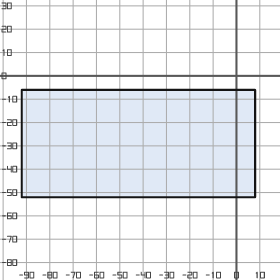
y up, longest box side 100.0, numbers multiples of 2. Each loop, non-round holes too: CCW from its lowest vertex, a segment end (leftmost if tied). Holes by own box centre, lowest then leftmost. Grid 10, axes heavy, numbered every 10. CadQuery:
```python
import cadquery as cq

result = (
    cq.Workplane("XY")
    .moveTo(-92.0, -52.0)
    .lineTo(8.0, -52.0)
    .lineTo(8.0, -6.0)
    .lineTo(-92.0, -6.0)
    .close()
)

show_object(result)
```